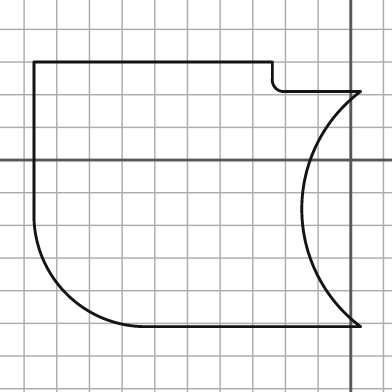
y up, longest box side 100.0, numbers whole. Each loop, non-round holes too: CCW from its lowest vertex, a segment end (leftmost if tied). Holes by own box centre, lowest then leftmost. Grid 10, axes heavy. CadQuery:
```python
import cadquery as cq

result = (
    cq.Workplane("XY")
    .moveTo(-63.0, -51.0)
    .lineTo(3.0, -51.0)
    .threePointArc((-15.0, -15.0), (3.0, 21.0))
    .lineTo(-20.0, 21.0)
    .threePointArc((-23.0, 22.0), (-24.0, 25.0))
    .lineTo(-24.0, 30.0)
    .lineTo(-97.0, 30.0)
    .lineTo(-97.0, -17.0)
    .threePointArc((-87.0, -41.0), (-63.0, -51.0))
    .close()
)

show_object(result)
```